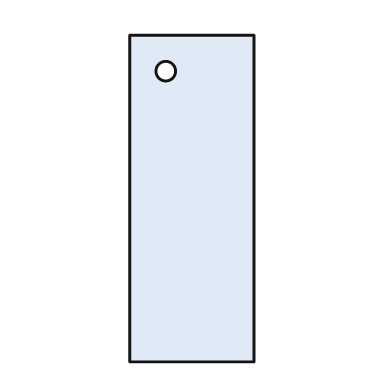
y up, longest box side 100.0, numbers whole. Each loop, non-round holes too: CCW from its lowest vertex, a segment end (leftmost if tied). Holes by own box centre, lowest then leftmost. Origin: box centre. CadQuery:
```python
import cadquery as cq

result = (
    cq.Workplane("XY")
    .moveTo(-19.0, -50.0)
    .lineTo(19.0, -50.0)
    .lineTo(19.0, 50.0)
    .lineTo(-19.0, 50.0)
    .close()
    .moveTo(-8.0, 39.0)
    .circle(3.0)
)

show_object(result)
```